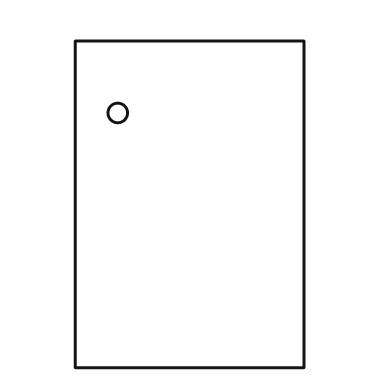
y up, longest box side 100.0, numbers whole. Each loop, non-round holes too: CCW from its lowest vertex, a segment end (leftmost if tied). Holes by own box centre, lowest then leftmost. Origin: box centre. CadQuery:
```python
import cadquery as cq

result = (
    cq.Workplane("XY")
    .moveTo(-35.0, -50.0)
    .lineTo(35.0, -50.0)
    .lineTo(35.0, 50.0)
    .lineTo(-35.0, 50.0)
    .close()
    .moveTo(-22.0, 28.0)
    .circle(3.0)
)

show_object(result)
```